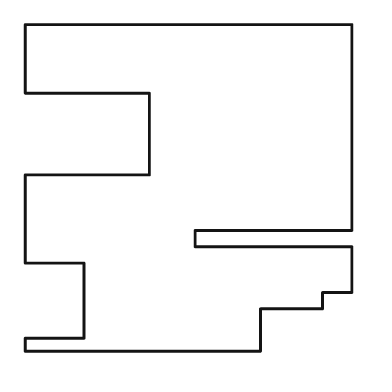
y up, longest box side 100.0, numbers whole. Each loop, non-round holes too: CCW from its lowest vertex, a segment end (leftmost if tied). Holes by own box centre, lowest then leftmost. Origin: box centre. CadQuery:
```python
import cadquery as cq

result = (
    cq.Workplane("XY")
    .moveTo(-50.0, -50.0)
    .lineTo(22.0, -50.0)
    .lineTo(22.0, -37.0)
    .lineTo(41.0, -37.0)
    .lineTo(41.0, -32.0)
    .lineTo(50.0, -32.0)
    .lineTo(50.0, -18.0)
    .lineTo(2.0, -18.0)
    .lineTo(2.0, -13.0)
    .lineTo(50.0, -13.0)
    .lineTo(50.0, 50.0)
    .lineTo(-50.0, 50.0)
    .lineTo(-50.0, 29.0)
    .lineTo(-12.0, 29.0)
    .lineTo(-12.0, 4.0)
    .lineTo(-50.0, 4.0)
    .lineTo(-50.0, -23.0)
    .lineTo(-32.0, -23.0)
    .lineTo(-32.0, -46.0)
    .lineTo(-50.0, -46.0)
    .close()
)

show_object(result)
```